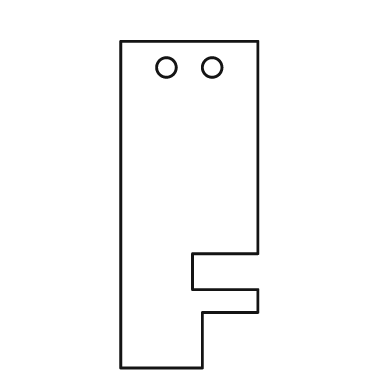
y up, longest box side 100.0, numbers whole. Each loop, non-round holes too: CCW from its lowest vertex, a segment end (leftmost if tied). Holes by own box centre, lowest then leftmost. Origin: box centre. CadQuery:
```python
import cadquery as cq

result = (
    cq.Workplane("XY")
    .moveTo(-21.0, -50.0)
    .lineTo(4.0, -50.0)
    .lineTo(4.0, -33.0)
    .lineTo(21.0, -33.0)
    .lineTo(21.0, -26.0)
    .lineTo(1.0, -26.0)
    .lineTo(1.0, -15.0)
    .lineTo(21.0, -15.0)
    .lineTo(21.0, 50.0)
    .lineTo(-21.0, 50.0)
    .close()
    .moveTo(-7.0, 42.0)
    .circle(3.0)
    .moveTo(7.0, 42.0)
    .circle(3.0)
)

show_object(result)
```